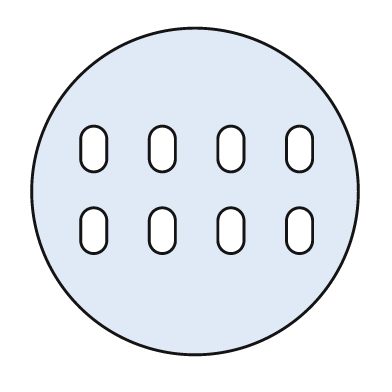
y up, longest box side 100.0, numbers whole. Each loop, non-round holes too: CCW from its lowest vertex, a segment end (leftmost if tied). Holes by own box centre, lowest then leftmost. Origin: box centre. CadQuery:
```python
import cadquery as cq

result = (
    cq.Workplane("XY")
    .moveTo(0.0, 0.0)
    .circle(50.0)
    .moveTo(-35.0, -15.0)
    .threePointArc((-31.0, -19.0), (-27.0, -15.0))
    .lineTo(-27.0, -9.0)
    .threePointArc((-31.0, -5.0), (-35.0, -9.0))
    .close()
    .moveTo(-14.0, -15.0)
    .threePointArc((-10.0, -19.0), (-6.0, -15.0))
    .lineTo(-6.0, -9.0)
    .threePointArc((-10.0, -5.0), (-14.0, -9.0))
    .close()
    .moveTo(7.0, -15.0)
    .threePointArc((11.0, -19.0), (15.0, -15.0))
    .lineTo(15.0, -9.0)
    .threePointArc((11.0, -5.0), (7.0, -9.0))
    .close()
    .moveTo(28.0, -15.0)
    .threePointArc((32.0, -19.0), (36.0, -15.0))
    .lineTo(36.0, -9.0)
    .threePointArc((32.0, -5.0), (28.0, -9.0))
    .close()
    .moveTo(-35.0, 10.0)
    .threePointArc((-31.0, 6.0), (-27.0, 10.0))
    .lineTo(-27.0, 16.0)
    .threePointArc((-31.0, 20.0), (-35.0, 16.0))
    .close()
    .moveTo(-14.0, 10.0)
    .threePointArc((-10.0, 6.0), (-6.0, 10.0))
    .lineTo(-6.0, 16.0)
    .threePointArc((-10.0, 20.0), (-14.0, 16.0))
    .close()
    .moveTo(7.0, 10.0)
    .threePointArc((11.0, 6.0), (15.0, 10.0))
    .lineTo(15.0, 16.0)
    .threePointArc((11.0, 20.0), (7.0, 16.0))
    .close()
    .moveTo(28.0, 10.0)
    .threePointArc((32.0, 6.0), (36.0, 10.0))
    .lineTo(36.0, 16.0)
    .threePointArc((32.0, 20.0), (28.0, 16.0))
    .close()
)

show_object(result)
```